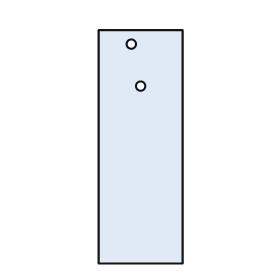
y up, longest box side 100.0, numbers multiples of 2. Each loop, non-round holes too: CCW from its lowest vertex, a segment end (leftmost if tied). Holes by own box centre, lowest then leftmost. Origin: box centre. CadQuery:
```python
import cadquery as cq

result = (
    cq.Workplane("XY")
    .moveTo(-18.0, -50.0)
    .lineTo(18.0, -50.0)
    .lineTo(18.0, 50.0)
    .lineTo(-18.0, 50.0)
    .close()
    .moveTo(0.0, 26.0)
    .circle(2.0)
    .moveTo(-4.0, 44.0)
    .circle(2.0)
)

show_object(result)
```